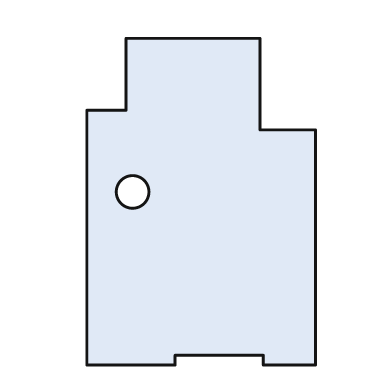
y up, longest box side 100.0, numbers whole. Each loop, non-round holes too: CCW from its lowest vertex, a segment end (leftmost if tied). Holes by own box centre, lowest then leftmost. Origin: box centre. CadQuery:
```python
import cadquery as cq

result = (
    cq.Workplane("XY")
    .moveTo(-35.0, -50.0)
    .lineTo(-8.0, -50.0)
    .lineTo(-8.0, -47.0)
    .lineTo(19.0, -47.0)
    .lineTo(19.0, -50.0)
    .lineTo(35.0, -50.0)
    .lineTo(35.0, 22.0)
    .lineTo(18.0, 22.0)
    .lineTo(18.0, 50.0)
    .lineTo(-23.0, 50.0)
    .lineTo(-23.0, 28.0)
    .lineTo(-35.0, 28.0)
    .close()
    .moveTo(-21.0, 3.0)
    .circle(5.0)
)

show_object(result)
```